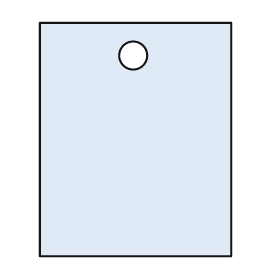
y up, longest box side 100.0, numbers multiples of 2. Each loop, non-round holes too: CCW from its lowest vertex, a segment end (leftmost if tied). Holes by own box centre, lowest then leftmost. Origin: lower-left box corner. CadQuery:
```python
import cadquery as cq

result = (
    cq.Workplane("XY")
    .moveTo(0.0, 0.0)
    .lineTo(82.0, 0.0)
    .lineTo(82.0, 100.0)
    .lineTo(0.0, 100.0)
    .close()
    .moveTo(40.0, 86.0)
    .circle(6.0)
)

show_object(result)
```